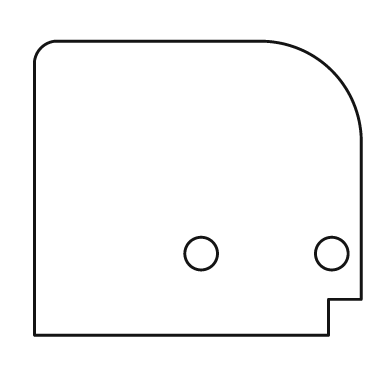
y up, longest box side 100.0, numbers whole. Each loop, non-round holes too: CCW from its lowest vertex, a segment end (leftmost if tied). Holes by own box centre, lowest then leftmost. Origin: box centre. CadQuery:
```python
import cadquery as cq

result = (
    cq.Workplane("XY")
    .moveTo(-50.0, -45.0)
    .lineTo(40.0, -45.0)
    .lineTo(40.0, -34.0)
    .lineTo(50.0, -34.0)
    .lineTo(50.0, 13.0)
    .threePointArc((41.0, 36.0), (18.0, 45.0))
    .lineTo(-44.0, 45.0)
    .threePointArc((-48.0, 43.0), (-50.0, 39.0))
    .close()
    .moveTo(1.0, -20.0)
    .circle(5.0)
    .moveTo(41.0, -20.0)
    .circle(5.0)
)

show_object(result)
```